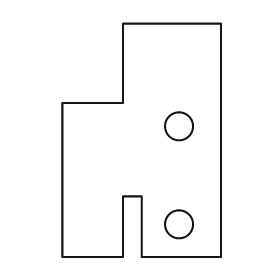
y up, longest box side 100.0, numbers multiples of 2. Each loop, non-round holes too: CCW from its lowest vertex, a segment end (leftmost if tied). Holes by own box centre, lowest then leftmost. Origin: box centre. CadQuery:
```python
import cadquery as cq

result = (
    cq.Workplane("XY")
    .moveTo(-34.0, -50.0)
    .lineTo(-8.0, -50.0)
    .lineTo(-8.0, -24.0)
    .lineTo(0.0, -24.0)
    .lineTo(0.0, -50.0)
    .lineTo(34.0, -50.0)
    .lineTo(34.0, 50.0)
    .lineTo(-8.0, 50.0)
    .lineTo(-8.0, 16.0)
    .lineTo(-34.0, 16.0)
    .close()
    .moveTo(16.0, -36.0)
    .circle(6.0)
    .moveTo(16.0, 6.0)
    .circle(6.0)
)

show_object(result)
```